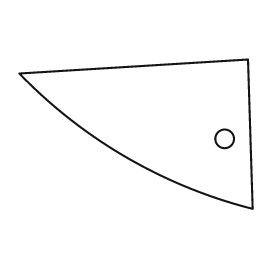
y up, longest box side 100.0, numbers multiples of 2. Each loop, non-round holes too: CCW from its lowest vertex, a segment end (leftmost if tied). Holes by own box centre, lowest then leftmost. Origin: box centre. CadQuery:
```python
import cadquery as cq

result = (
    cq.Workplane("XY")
    .moveTo(50.0, -32.0)
    .lineTo(48.0, 32.0)
    .lineTo(-50.0, 26.0)
    .threePointArc((-4.0, -10.0), (50.0, -32.0))
    .close()
    .moveTo(38.0, -2.0)
    .circle(4.0)
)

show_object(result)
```